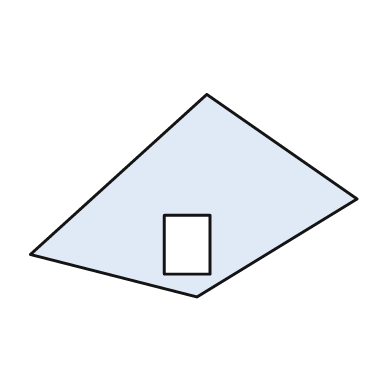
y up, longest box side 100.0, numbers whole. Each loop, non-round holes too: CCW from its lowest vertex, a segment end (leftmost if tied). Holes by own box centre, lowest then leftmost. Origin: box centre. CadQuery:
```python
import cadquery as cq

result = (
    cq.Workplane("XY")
    .moveTo(1.0, -31.0)
    .lineTo(50.0, -1.0)
    .lineTo(4.0, 31.0)
    .lineTo(-50.0, -18.0)
    .close()
    .moveTo(-9.0, -24.0)
    .lineTo(5.0, -24.0)
    .lineTo(5.0, -6.0)
    .lineTo(-9.0, -6.0)
    .close()
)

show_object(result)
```